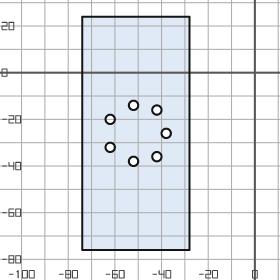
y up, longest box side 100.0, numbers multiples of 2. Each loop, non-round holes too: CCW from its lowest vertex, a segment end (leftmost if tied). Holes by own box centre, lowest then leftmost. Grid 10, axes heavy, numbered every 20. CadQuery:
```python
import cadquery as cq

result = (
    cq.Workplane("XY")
    .moveTo(-74.0, -76.0)
    .lineTo(-28.0, -76.0)
    .lineTo(-28.0, 24.0)
    .lineTo(-74.0, 24.0)
    .close()
    .moveTo(-52.0, -38.0)
    .circle(2.0)
    .moveTo(-42.0, -36.0)
    .circle(2.0)
    .moveTo(-62.0, -32.0)
    .circle(2.0)
    .moveTo(-38.0, -26.0)
    .circle(2.0)
    .moveTo(-62.0, -20.0)
    .circle(2.0)
    .moveTo(-42.0, -16.0)
    .circle(2.0)
    .moveTo(-52.0, -14.0)
    .circle(2.0)
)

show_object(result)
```